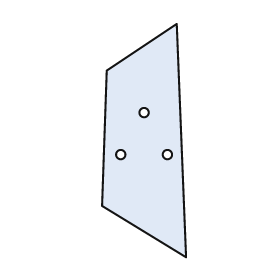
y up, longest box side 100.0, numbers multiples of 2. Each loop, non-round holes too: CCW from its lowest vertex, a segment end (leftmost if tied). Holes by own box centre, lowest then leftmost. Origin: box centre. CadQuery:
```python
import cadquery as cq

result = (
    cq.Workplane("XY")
    .moveTo(18.0, -50.0)
    .lineTo(14.0, 50.0)
    .lineTo(-16.0, 30.0)
    .lineTo(-18.0, -28.0)
    .close()
    .moveTo(-10.0, -6.0)
    .circle(2.0)
    .moveTo(10.0, -6.0)
    .circle(2.0)
    .moveTo(0.0, 12.0)
    .circle(2.0)
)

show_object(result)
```